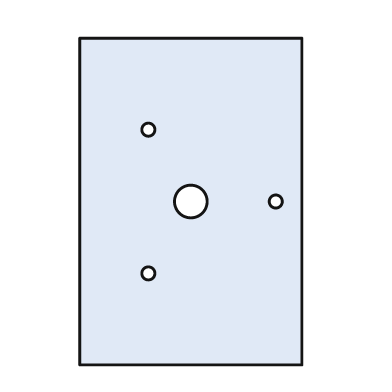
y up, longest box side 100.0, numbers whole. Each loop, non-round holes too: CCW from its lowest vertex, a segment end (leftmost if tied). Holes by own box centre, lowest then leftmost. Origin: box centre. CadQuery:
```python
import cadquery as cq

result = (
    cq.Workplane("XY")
    .moveTo(-34.0, -50.0)
    .lineTo(34.0, -50.0)
    .lineTo(34.0, 50.0)
    .lineTo(-34.0, 50.0)
    .close()
    .moveTo(-13.0, -22.0)
    .circle(2.0)
    .moveTo(0.0, 0.0)
    .circle(5.0)
    .moveTo(26.0, 0.0)
    .circle(2.0)
    .moveTo(-13.0, 22.0)
    .circle(2.0)
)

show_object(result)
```